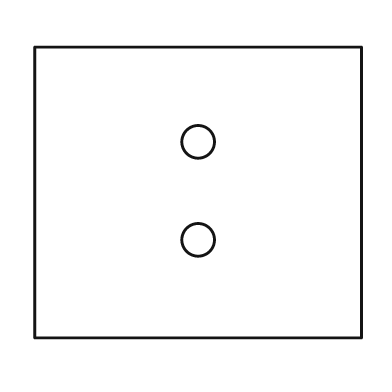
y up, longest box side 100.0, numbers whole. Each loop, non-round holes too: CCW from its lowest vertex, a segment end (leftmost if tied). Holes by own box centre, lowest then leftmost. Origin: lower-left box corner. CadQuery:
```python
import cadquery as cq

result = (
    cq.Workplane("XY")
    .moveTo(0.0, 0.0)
    .lineTo(100.0, 0.0)
    .lineTo(100.0, 89.0)
    .lineTo(0.0, 89.0)
    .close()
    .moveTo(50.0, 30.0)
    .circle(5.0)
    .moveTo(50.0, 60.0)
    .circle(5.0)
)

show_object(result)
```